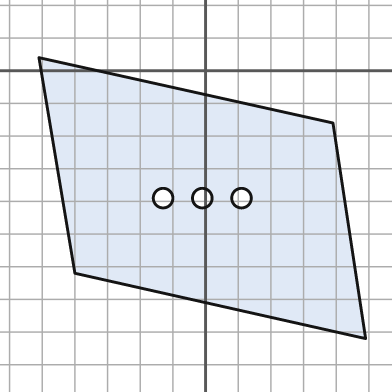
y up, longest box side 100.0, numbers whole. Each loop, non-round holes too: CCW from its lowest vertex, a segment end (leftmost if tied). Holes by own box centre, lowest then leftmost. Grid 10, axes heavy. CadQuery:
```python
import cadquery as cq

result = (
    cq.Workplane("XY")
    .moveTo(49.0, -82.0)
    .lineTo(39.0, -16.0)
    .lineTo(-51.0, 4.0)
    .lineTo(-40.0, -62.0)
    .close()
    .moveTo(-13.0, -39.0)
    .circle(3.0)
    .moveTo(-1.0, -39.0)
    .circle(3.0)
    .moveTo(11.0, -39.0)
    .circle(3.0)
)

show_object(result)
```